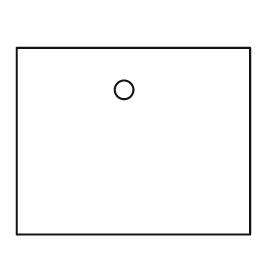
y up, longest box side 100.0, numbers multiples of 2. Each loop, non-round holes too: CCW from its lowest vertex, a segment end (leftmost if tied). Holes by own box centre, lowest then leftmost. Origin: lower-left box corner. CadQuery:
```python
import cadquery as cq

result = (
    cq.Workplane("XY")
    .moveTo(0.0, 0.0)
    .lineTo(100.0, 0.0)
    .lineTo(100.0, 80.0)
    .lineTo(0.0, 80.0)
    .close()
    .moveTo(46.0, 62.0)
    .circle(4.0)
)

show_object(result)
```